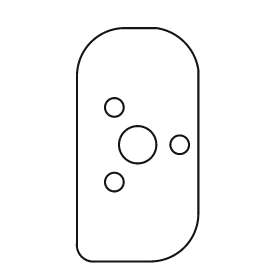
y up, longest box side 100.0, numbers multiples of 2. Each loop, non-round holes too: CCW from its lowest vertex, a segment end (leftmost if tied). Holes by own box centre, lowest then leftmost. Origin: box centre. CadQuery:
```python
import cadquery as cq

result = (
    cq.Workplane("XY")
    .moveTo(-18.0, -50.0)
    .lineTo(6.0, -50.0)
    .threePointArc((20.0, -44.0), (26.0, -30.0))
    .lineTo(26.0, 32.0)
    .threePointArc((20.0, 44.0), (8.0, 50.0))
    .lineTo(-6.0, 50.0)
    .threePointArc((-20.0, 44.0), (-26.0, 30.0))
    .lineTo(-26.0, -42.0)
    .threePointArc((-24.0, -48.0), (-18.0, -50.0))
    .close()
    .moveTo(-10.0, -16.0)
    .circle(4.0)
    .moveTo(0.0, 0.0)
    .circle(8.0)
    .moveTo(18.0, 0.0)
    .circle(4.0)
    .moveTo(-10.0, 16.0)
    .circle(4.0)
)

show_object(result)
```